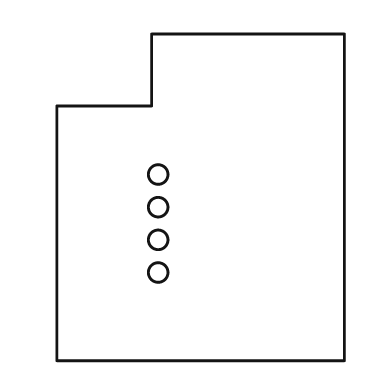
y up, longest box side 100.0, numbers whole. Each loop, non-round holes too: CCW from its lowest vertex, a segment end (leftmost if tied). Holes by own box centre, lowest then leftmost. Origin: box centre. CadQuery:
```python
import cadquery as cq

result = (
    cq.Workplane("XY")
    .moveTo(-44.0, -50.0)
    .lineTo(44.0, -50.0)
    .lineTo(44.0, 50.0)
    .lineTo(-15.0, 50.0)
    .lineTo(-15.0, 28.0)
    .lineTo(-44.0, 28.0)
    .close()
    .moveTo(-13.0, -23.0)
    .circle(3.0)
    .moveTo(-13.0, -13.0)
    .circle(3.0)
    .moveTo(-13.0, -3.0)
    .circle(3.0)
    .moveTo(-13.0, 7.0)
    .circle(3.0)
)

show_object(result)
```